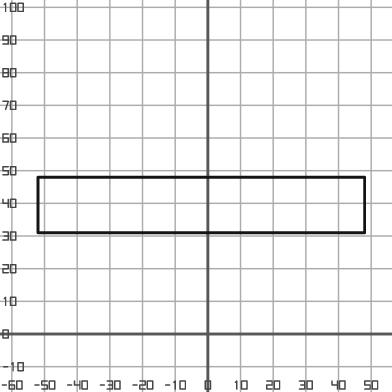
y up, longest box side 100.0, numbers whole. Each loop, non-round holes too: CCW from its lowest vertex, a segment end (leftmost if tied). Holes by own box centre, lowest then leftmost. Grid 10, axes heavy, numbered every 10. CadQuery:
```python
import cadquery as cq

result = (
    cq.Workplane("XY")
    .moveTo(-52.0, 31.0)
    .lineTo(48.0, 31.0)
    .lineTo(48.0, 48.0)
    .lineTo(-52.0, 48.0)
    .close()
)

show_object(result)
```